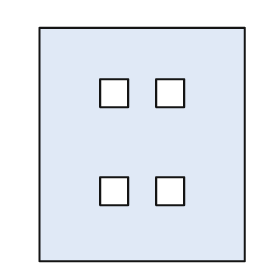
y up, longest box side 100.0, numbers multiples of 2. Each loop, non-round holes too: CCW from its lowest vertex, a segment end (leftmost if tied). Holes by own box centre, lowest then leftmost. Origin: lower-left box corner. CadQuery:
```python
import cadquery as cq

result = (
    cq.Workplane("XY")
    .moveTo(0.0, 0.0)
    .lineTo(88.0, 0.0)
    .lineTo(88.0, 100.0)
    .lineTo(0.0, 100.0)
    .close()
    .moveTo(26.0, 24.0)
    .lineTo(38.0, 24.0)
    .lineTo(38.0, 36.0)
    .lineTo(26.0, 36.0)
    .close()
    .moveTo(50.0, 24.0)
    .lineTo(62.0, 24.0)
    .lineTo(62.0, 36.0)
    .lineTo(50.0, 36.0)
    .close()
    .moveTo(26.0, 66.0)
    .lineTo(38.0, 66.0)
    .lineTo(38.0, 78.0)
    .lineTo(26.0, 78.0)
    .close()
    .moveTo(50.0, 66.0)
    .lineTo(62.0, 66.0)
    .lineTo(62.0, 78.0)
    .lineTo(50.0, 78.0)
    .close()
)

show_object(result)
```